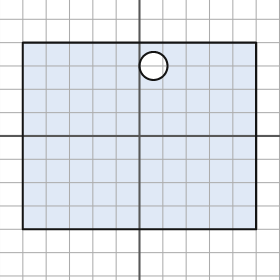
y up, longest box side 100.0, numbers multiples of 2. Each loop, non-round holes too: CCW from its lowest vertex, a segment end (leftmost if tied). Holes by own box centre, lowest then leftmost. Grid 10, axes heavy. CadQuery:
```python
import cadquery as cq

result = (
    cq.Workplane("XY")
    .moveTo(-50.0, -40.0)
    .lineTo(50.0, -40.0)
    .lineTo(50.0, 40.0)
    .lineTo(-50.0, 40.0)
    .close()
    .moveTo(6.0, 30.0)
    .circle(6.0)
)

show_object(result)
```